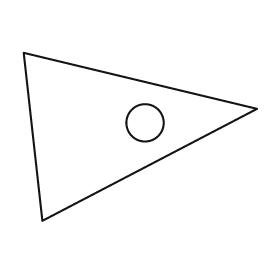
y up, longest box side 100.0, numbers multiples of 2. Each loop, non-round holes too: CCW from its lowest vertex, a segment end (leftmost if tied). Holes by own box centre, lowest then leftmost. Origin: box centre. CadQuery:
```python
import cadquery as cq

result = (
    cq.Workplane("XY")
    .moveTo(-42.0, -36.0)
    .lineTo(50.0, 12.0)
    .lineTo(-50.0, 36.0)
    .close()
    .moveTo(2.0, 6.0)
    .circle(8.0)
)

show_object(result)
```